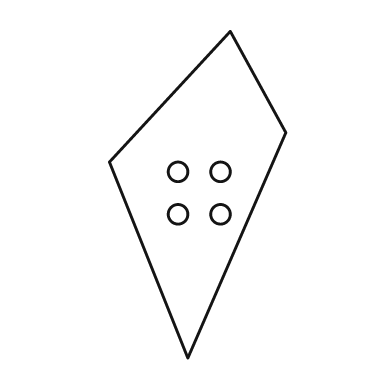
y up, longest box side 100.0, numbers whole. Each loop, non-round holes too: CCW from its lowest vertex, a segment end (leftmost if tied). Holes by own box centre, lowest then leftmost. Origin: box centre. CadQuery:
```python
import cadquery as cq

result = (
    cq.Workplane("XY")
    .moveTo(-3.0, -50.0)
    .lineTo(27.0, 19.0)
    .lineTo(10.0, 50.0)
    .lineTo(-27.0, 10.0)
    .close()
    .moveTo(-6.0, -6.0)
    .circle(3.0)
    .moveTo(7.0, -6.0)
    .circle(3.0)
    .moveTo(-6.0, 7.0)
    .circle(3.0)
    .moveTo(7.0, 7.0)
    .circle(3.0)
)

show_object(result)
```